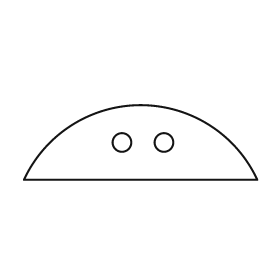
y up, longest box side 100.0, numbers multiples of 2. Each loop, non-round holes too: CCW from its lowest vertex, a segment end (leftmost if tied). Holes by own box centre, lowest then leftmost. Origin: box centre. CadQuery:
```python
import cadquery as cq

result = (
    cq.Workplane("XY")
    .moveTo(-50.0, -16.0)
    .lineTo(50.0, -16.0)
    .threePointArc((0.0, 16.0), (-50.0, -16.0))
    .close()
    .moveTo(-8.0, 0.0)
    .circle(4.0)
    .moveTo(10.0, 0.0)
    .circle(4.0)
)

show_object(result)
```